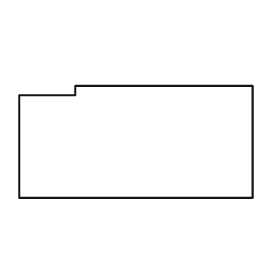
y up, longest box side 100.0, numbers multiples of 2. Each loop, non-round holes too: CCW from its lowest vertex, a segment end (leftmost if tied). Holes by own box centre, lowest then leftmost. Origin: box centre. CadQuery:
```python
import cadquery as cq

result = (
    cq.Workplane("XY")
    .moveTo(-50.0, -24.0)
    .lineTo(50.0, -24.0)
    .lineTo(50.0, 24.0)
    .lineTo(-26.0, 24.0)
    .lineTo(-26.0, 20.0)
    .lineTo(-50.0, 20.0)
    .close()
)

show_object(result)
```